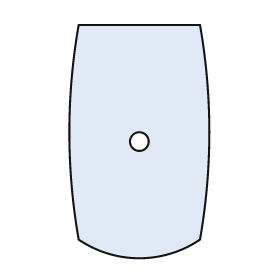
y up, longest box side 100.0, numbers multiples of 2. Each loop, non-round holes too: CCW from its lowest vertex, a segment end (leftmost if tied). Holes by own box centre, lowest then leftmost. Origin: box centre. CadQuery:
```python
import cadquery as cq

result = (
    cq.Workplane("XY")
    .moveTo(-26.0, -42.0)
    .threePointArc((0.0, -50.0), (26.0, -42.0))
    .threePointArc((30.0, 4.0), (26.0, 50.0))
    .lineTo(-26.0, 50.0)
    .threePointArc((-30.0, 4.0), (-26.0, -42.0))
    .close()
    .moveTo(0.0, 0.0)
    .circle(4.0)
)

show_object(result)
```